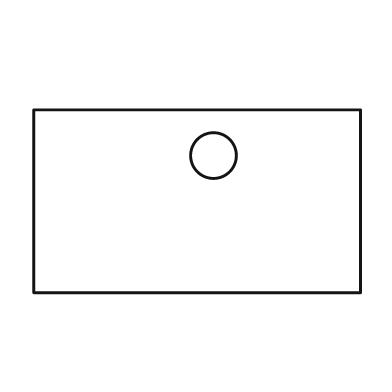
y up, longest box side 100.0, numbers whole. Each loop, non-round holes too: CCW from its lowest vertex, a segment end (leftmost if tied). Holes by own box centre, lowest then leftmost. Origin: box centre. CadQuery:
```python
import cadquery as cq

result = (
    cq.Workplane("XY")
    .moveTo(-50.0, -28.0)
    .lineTo(50.0, -28.0)
    .lineTo(50.0, 28.0)
    .lineTo(-50.0, 28.0)
    .close()
    .moveTo(5.0, 14.0)
    .circle(7.0)
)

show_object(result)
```